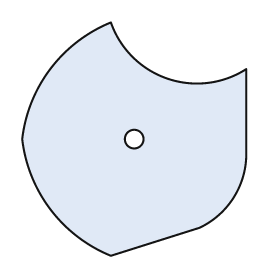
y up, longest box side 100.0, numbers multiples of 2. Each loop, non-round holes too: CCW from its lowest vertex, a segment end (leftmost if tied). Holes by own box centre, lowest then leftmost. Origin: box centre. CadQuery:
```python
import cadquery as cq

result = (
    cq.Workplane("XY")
    .moveTo(-10.0, -50.0)
    .lineTo(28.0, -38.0)
    .threePointArc((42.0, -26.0), (48.0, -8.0))
    .lineTo(48.0, 30.0)
    .threePointArc((14.0, 26.0), (-10.0, 50.0))
    .threePointArc((-36.0, 30.0), (-48.0, 0.0))
    .threePointArc((-36.0, -30.0), (-10.0, -50.0))
    .close()
    .moveTo(0.0, 0.0)
    .circle(4.0)
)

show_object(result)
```